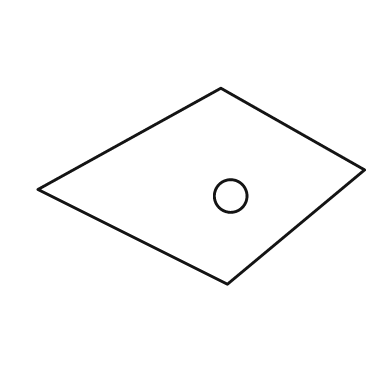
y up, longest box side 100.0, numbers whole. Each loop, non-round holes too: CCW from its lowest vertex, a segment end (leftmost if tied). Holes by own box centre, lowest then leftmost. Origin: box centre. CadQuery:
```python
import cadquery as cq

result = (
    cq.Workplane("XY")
    .moveTo(8.0, -30.0)
    .lineTo(50.0, 5.0)
    .lineTo(6.0, 30.0)
    .lineTo(-50.0, -1.0)
    .close()
    .moveTo(9.0, -3.0)
    .circle(5.0)
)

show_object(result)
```